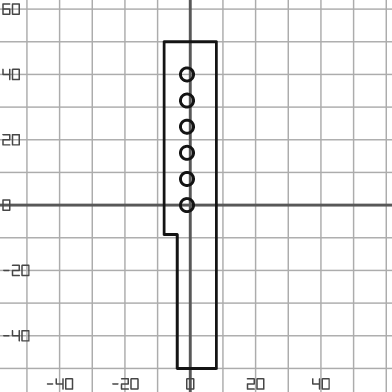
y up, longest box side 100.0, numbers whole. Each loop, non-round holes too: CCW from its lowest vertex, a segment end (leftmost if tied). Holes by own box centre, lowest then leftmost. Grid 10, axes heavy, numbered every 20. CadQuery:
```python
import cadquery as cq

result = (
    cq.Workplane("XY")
    .moveTo(-4.0, -50.0)
    .lineTo(8.0, -50.0)
    .lineTo(8.0, 50.0)
    .lineTo(-8.0, 50.0)
    .lineTo(-8.0, -9.0)
    .lineTo(-4.0, -9.0)
    .close()
    .moveTo(-1.0, 0.0)
    .circle(2.0)
    .moveTo(-1.0, 8.0)
    .circle(2.0)
    .moveTo(-1.0, 16.0)
    .circle(2.0)
    .moveTo(-1.0, 24.0)
    .circle(2.0)
    .moveTo(-1.0, 32.0)
    .circle(2.0)
    .moveTo(-1.0, 40.0)
    .circle(2.0)
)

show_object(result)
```